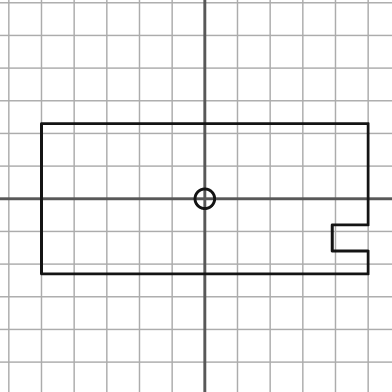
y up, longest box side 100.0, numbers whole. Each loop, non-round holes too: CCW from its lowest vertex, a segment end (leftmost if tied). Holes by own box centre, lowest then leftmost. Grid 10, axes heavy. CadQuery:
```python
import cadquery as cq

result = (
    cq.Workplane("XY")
    .moveTo(-50.0, -23.0)
    .lineTo(50.0, -23.0)
    .lineTo(50.0, -16.0)
    .lineTo(39.0, -16.0)
    .lineTo(39.0, -8.0)
    .lineTo(50.0, -8.0)
    .lineTo(50.0, 23.0)
    .lineTo(-50.0, 23.0)
    .close()
    .moveTo(0.0, 0.0)
    .circle(3.0)
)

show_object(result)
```